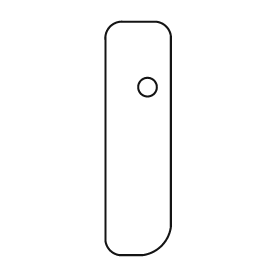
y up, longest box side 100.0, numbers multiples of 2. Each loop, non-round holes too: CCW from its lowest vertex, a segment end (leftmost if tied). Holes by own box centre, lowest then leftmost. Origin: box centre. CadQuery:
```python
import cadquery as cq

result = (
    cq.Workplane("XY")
    .moveTo(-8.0, -50.0)
    .lineTo(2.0, -50.0)
    .threePointArc((10.0, -46.0), (14.0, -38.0))
    .lineTo(14.0, 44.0)
    .threePointArc((12.0, 48.0), (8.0, 50.0))
    .lineTo(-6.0, 50.0)
    .threePointArc((-12.0, 48.0), (-14.0, 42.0))
    .lineTo(-14.0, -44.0)
    .threePointArc((-12.0, -48.0), (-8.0, -50.0))
    .close()
    .moveTo(4.0, 22.0)
    .circle(4.0)
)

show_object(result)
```